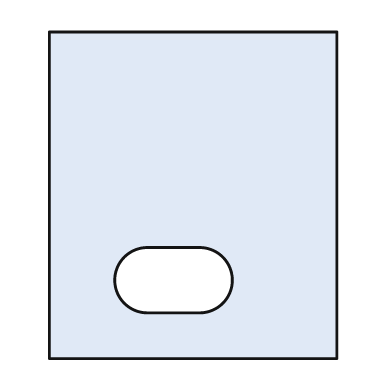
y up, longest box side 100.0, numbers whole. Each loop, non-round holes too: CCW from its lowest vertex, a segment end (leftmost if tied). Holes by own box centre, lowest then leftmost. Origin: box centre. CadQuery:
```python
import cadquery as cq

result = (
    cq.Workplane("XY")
    .moveTo(-44.0, -50.0)
    .lineTo(44.0, -50.0)
    .lineTo(44.0, 50.0)
    .lineTo(-44.0, 50.0)
    .close()
    .moveTo(-14.0, -36.0)
    .lineTo(2.0, -36.0)
    .threePointArc((12.0, -26.0), (2.0, -16.0))
    .lineTo(-14.0, -16.0)
    .threePointArc((-24.0, -26.0), (-14.0, -36.0))
    .close()
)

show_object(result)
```